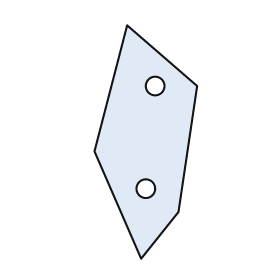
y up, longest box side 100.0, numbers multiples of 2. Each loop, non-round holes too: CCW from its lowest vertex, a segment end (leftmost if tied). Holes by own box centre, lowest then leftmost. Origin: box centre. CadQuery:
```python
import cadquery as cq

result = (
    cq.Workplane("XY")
    .moveTo(-2.0, -50.0)
    .lineTo(14.0, -30.0)
    .lineTo(22.0, 24.0)
    .lineTo(-8.0, 50.0)
    .lineTo(-22.0, -4.0)
    .close()
    .moveTo(0.0, -20.0)
    .circle(4.0)
    .moveTo(4.0, 24.0)
    .circle(4.0)
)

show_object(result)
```